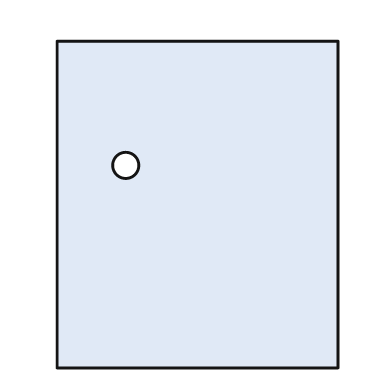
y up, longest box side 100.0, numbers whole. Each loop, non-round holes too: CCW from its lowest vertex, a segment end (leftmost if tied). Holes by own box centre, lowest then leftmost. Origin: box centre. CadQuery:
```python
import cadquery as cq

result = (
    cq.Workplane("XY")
    .moveTo(-43.0, -50.0)
    .lineTo(43.0, -50.0)
    .lineTo(43.0, 50.0)
    .lineTo(-43.0, 50.0)
    .close()
    .moveTo(-22.0, 12.0)
    .circle(4.0)
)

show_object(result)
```